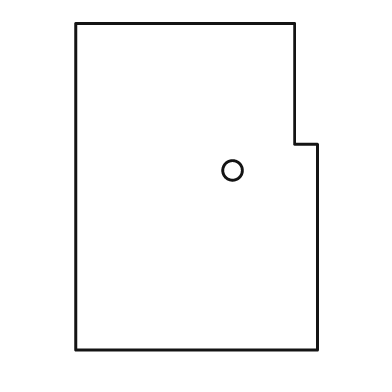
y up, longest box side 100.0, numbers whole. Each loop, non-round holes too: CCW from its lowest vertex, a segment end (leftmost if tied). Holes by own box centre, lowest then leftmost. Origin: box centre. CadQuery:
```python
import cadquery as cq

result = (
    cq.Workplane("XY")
    .moveTo(-37.0, -50.0)
    .lineTo(37.0, -50.0)
    .lineTo(37.0, 13.0)
    .lineTo(30.0, 13.0)
    .lineTo(30.0, 50.0)
    .lineTo(-37.0, 50.0)
    .close()
    .moveTo(11.0, 5.0)
    .circle(3.0)
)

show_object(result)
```